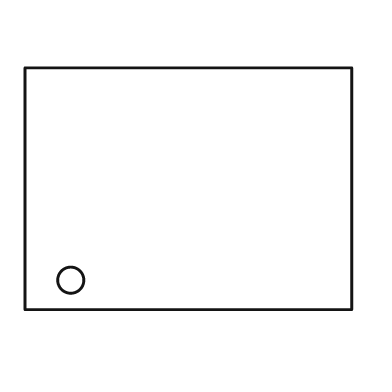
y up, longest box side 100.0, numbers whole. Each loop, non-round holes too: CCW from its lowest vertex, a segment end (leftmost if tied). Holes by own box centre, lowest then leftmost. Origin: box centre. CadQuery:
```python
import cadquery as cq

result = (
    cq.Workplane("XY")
    .moveTo(-50.0, -37.0)
    .lineTo(50.0, -37.0)
    .lineTo(50.0, 37.0)
    .lineTo(-50.0, 37.0)
    .close()
    .moveTo(-36.0, -28.0)
    .circle(4.0)
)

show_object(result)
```